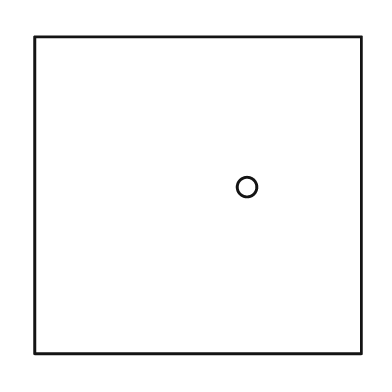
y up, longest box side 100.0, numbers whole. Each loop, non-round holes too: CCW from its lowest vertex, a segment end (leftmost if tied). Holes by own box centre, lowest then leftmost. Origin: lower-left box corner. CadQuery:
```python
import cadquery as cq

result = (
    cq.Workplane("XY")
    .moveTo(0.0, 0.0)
    .lineTo(100.0, 0.0)
    .lineTo(100.0, 97.0)
    .lineTo(0.0, 97.0)
    .close()
    .moveTo(65.0, 51.0)
    .circle(3.0)
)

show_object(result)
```